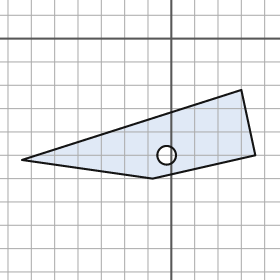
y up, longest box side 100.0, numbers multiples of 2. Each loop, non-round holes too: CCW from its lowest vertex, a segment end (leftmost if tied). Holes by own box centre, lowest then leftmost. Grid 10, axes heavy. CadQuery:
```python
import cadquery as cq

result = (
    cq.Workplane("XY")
    .moveTo(-8.0, -60.0)
    .lineTo(36.0, -50.0)
    .lineTo(30.0, -22.0)
    .lineTo(-64.0, -52.0)
    .close()
    .moveTo(-2.0, -50.0)
    .circle(4.0)
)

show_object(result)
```